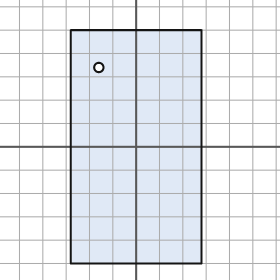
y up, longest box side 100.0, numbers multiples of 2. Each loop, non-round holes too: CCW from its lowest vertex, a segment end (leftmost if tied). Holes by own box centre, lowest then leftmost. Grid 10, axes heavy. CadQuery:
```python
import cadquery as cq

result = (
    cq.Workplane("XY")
    .moveTo(-28.0, -50.0)
    .lineTo(28.0, -50.0)
    .lineTo(28.0, 50.0)
    .lineTo(-28.0, 50.0)
    .close()
    .moveTo(-16.0, 34.0)
    .circle(2.0)
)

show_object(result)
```